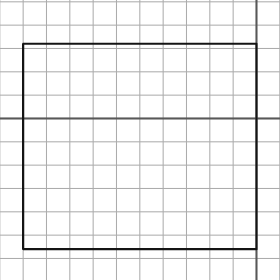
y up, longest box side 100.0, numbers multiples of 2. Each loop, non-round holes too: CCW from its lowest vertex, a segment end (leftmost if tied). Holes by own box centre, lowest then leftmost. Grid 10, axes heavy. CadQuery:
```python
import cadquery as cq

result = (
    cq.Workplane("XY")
    .moveTo(-100.0, -56.0)
    .lineTo(0.0, -56.0)
    .lineTo(0.0, 32.0)
    .lineTo(-100.0, 32.0)
    .close()
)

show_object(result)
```